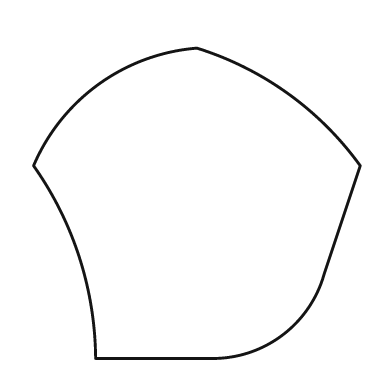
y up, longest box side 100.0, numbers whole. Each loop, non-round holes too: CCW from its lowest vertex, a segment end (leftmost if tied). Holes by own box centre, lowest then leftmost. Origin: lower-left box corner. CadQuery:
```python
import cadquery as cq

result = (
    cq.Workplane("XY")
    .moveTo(19.0, 0.0)
    .lineTo(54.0, 0.0)
    .threePointArc((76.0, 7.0), (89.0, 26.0))
    .lineTo(100.0, 59.0)
    .threePointArc((78.0, 81.0), (50.0, 95.0))
    .threePointArc((20.0, 84.0), (0.0, 59.0))
    .threePointArc((14.0, 31.0), (19.0, 0.0))
    .close()
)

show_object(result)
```